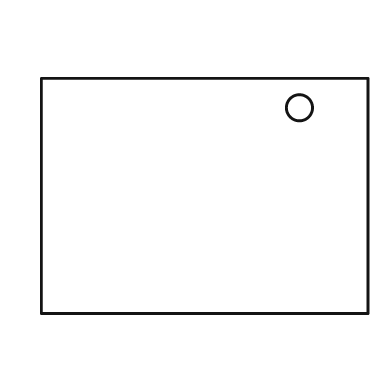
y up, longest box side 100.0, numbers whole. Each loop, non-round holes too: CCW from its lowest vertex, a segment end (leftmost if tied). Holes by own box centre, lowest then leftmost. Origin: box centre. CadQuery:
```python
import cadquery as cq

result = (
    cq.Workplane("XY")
    .moveTo(-50.0, -36.0)
    .lineTo(50.0, -36.0)
    .lineTo(50.0, 36.0)
    .lineTo(-50.0, 36.0)
    .close()
    .moveTo(29.0, 27.0)
    .circle(4.0)
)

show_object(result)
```